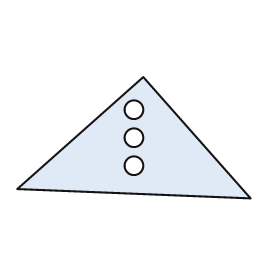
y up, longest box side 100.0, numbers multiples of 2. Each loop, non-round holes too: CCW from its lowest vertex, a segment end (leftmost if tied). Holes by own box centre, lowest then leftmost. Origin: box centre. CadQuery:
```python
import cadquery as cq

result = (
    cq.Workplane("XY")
    .moveTo(50.0, -26.0)
    .lineTo(4.0, 26.0)
    .lineTo(-50.0, -22.0)
    .close()
    .moveTo(0.0, -12.0)
    .circle(4.0)
    .moveTo(0.0, 0.0)
    .circle(4.0)
    .moveTo(0.0, 12.0)
    .circle(4.0)
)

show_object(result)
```